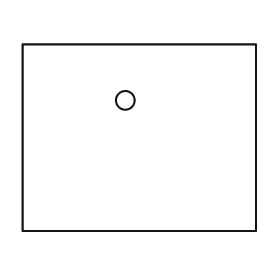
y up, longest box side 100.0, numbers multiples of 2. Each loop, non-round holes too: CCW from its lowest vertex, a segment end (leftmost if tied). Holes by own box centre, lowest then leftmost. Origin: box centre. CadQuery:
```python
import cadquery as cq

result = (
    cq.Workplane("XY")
    .moveTo(-50.0, -40.0)
    .lineTo(50.0, -40.0)
    .lineTo(50.0, 40.0)
    .lineTo(-50.0, 40.0)
    .close()
    .moveTo(-6.0, 16.0)
    .circle(4.0)
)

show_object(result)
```